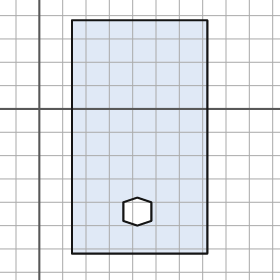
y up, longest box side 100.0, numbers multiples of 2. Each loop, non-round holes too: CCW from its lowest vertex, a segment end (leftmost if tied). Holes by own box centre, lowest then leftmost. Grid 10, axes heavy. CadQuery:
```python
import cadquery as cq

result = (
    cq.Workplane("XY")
    .moveTo(14.0, -62.0)
    .lineTo(72.0, -62.0)
    .lineTo(72.0, 38.0)
    .lineTo(14.0, 38.0)
    .close()
    .moveTo(42.0, -50.0)
    .lineTo(48.0, -48.0)
    .lineTo(48.0, -40.0)
    .lineTo(42.0, -38.0)
    .lineTo(36.0, -40.0)
    .lineTo(36.0, -48.0)
    .close()
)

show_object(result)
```